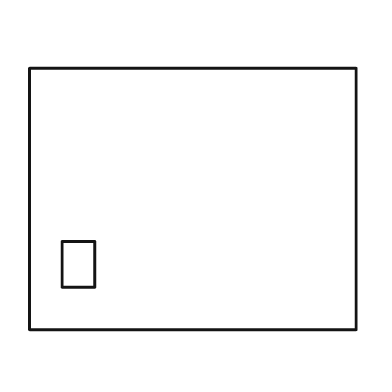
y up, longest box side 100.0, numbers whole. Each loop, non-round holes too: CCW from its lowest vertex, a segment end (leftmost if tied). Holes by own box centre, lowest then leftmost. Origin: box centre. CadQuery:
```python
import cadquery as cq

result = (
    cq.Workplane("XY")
    .moveTo(-50.0, -40.0)
    .lineTo(50.0, -40.0)
    .lineTo(50.0, 40.0)
    .lineTo(-50.0, 40.0)
    .close()
    .moveTo(-40.0, -27.0)
    .lineTo(-30.0, -27.0)
    .lineTo(-30.0, -13.0)
    .lineTo(-40.0, -13.0)
    .close()
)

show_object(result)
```